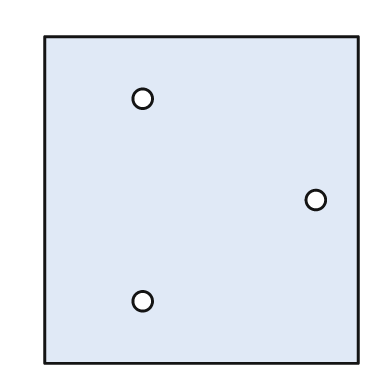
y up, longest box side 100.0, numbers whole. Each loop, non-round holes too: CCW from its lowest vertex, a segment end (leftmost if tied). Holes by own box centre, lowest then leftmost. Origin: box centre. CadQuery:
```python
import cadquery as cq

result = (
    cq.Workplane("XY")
    .moveTo(-48.0, -50.0)
    .lineTo(48.0, -50.0)
    .lineTo(48.0, 50.0)
    .lineTo(-48.0, 50.0)
    .close()
    .moveTo(-18.0, -31.0)
    .circle(3.0)
    .moveTo(35.0, 0.0)
    .circle(3.0)
    .moveTo(-18.0, 31.0)
    .circle(3.0)
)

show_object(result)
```